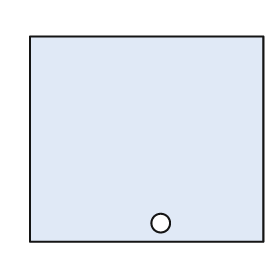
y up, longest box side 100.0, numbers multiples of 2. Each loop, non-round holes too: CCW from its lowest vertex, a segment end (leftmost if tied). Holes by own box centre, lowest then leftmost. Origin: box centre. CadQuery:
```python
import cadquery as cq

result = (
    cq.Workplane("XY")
    .moveTo(-50.0, -44.0)
    .lineTo(50.0, -44.0)
    .lineTo(50.0, 44.0)
    .lineTo(-50.0, 44.0)
    .close()
    .moveTo(6.0, -36.0)
    .circle(4.0)
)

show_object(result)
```